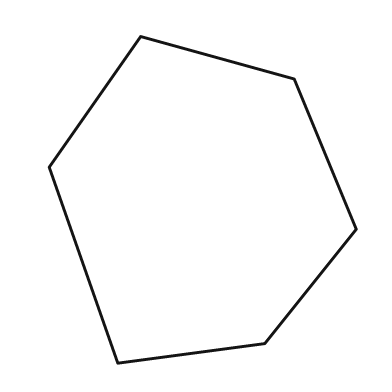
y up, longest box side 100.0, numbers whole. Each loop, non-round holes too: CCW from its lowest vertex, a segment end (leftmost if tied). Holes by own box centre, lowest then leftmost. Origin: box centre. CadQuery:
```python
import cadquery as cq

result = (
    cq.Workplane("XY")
    .moveTo(-26.0, -50.0)
    .lineTo(19.0, -44.0)
    .lineTo(47.0, -9.0)
    .lineTo(28.0, 37.0)
    .lineTo(-19.0, 50.0)
    .lineTo(-47.0, 10.0)
    .close()
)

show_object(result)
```